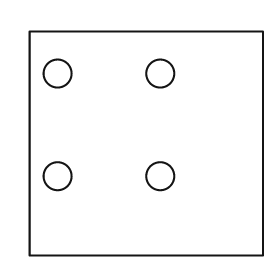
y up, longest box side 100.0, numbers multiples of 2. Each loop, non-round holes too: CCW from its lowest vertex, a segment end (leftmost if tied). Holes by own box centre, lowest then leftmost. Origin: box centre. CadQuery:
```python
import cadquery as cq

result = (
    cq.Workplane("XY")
    .moveTo(-50.0, -48.0)
    .lineTo(50.0, -48.0)
    .lineTo(50.0, 48.0)
    .lineTo(-50.0, 48.0)
    .close()
    .moveTo(-38.0, -14.0)
    .circle(6.0)
    .moveTo(6.0, -14.0)
    .circle(6.0)
    .moveTo(-38.0, 30.0)
    .circle(6.0)
    .moveTo(6.0, 30.0)
    .circle(6.0)
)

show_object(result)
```